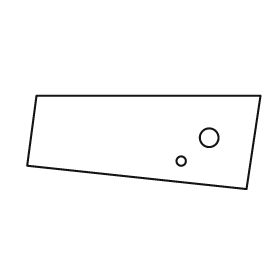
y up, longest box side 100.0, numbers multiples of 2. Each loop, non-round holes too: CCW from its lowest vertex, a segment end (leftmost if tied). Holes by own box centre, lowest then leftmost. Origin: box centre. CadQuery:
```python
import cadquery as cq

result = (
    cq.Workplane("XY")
    .moveTo(44.0, -20.0)
    .lineTo(50.0, 20.0)
    .lineTo(-46.0, 20.0)
    .lineTo(-50.0, -10.0)
    .close()
    .moveTo(16.0, -8.0)
    .circle(2.0)
    .moveTo(28.0, 2.0)
    .circle(4.0)
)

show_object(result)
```